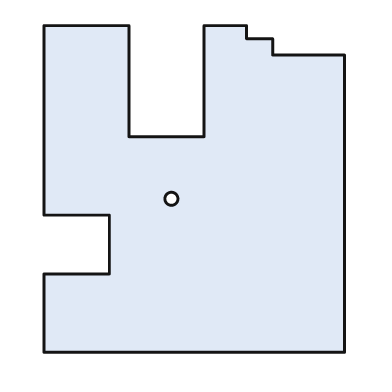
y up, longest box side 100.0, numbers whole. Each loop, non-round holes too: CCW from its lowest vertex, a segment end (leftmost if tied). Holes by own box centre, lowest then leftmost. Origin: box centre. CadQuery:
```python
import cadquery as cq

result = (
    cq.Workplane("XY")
    .moveTo(-46.0, -50.0)
    .lineTo(46.0, -50.0)
    .lineTo(46.0, 41.0)
    .lineTo(24.0, 41.0)
    .lineTo(24.0, 46.0)
    .lineTo(16.0, 46.0)
    .lineTo(16.0, 50.0)
    .lineTo(3.0, 50.0)
    .lineTo(3.0, 16.0)
    .lineTo(-20.0, 16.0)
    .lineTo(-20.0, 50.0)
    .lineTo(-46.0, 50.0)
    .lineTo(-46.0, -8.0)
    .lineTo(-26.0, -8.0)
    .lineTo(-26.0, -26.0)
    .lineTo(-46.0, -26.0)
    .close()
    .moveTo(-7.0, -3.0)
    .circle(2.0)
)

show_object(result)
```